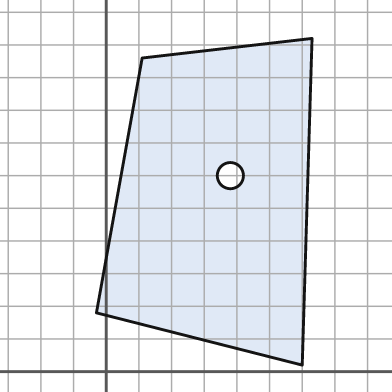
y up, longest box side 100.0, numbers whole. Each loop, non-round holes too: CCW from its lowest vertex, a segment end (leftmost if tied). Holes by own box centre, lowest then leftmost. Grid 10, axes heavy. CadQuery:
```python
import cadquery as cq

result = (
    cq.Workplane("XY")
    .moveTo(60.0, 2.0)
    .lineTo(63.0, 102.0)
    .lineTo(11.0, 96.0)
    .lineTo(-3.0, 18.0)
    .close()
    .moveTo(38.0, 60.0)
    .circle(4.0)
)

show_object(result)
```